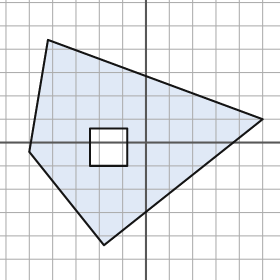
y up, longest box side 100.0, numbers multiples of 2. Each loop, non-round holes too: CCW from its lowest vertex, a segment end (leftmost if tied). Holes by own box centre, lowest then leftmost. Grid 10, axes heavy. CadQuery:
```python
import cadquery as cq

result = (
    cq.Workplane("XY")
    .moveTo(-18.0, -44.0)
    .lineTo(50.0, 10.0)
    .lineTo(-42.0, 44.0)
    .lineTo(-50.0, -4.0)
    .close()
    .moveTo(-24.0, -10.0)
    .lineTo(-8.0, -10.0)
    .lineTo(-8.0, 6.0)
    .lineTo(-24.0, 6.0)
    .close()
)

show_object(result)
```